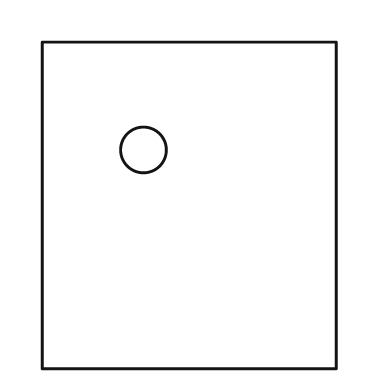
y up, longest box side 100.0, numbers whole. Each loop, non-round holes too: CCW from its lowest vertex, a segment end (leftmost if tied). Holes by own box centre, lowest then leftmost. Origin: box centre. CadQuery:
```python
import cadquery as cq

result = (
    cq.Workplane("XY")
    .moveTo(-45.0, -50.0)
    .lineTo(45.0, -50.0)
    .lineTo(45.0, 50.0)
    .lineTo(-45.0, 50.0)
    .close()
    .moveTo(-14.0, 17.0)
    .circle(7.0)
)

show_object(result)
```